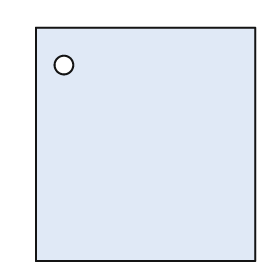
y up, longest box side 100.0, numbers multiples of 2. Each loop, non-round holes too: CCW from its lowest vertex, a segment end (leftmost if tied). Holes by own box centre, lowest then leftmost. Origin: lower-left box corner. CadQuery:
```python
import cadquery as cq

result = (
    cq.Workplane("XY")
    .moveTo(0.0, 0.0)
    .lineTo(94.0, 0.0)
    .lineTo(94.0, 100.0)
    .lineTo(0.0, 100.0)
    .close()
    .moveTo(12.0, 84.0)
    .circle(4.0)
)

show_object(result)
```